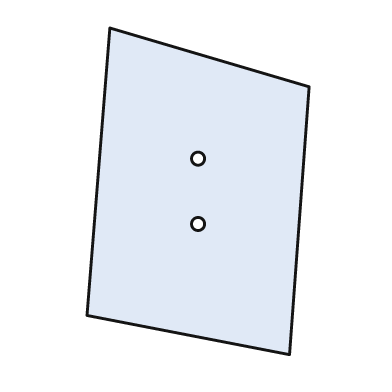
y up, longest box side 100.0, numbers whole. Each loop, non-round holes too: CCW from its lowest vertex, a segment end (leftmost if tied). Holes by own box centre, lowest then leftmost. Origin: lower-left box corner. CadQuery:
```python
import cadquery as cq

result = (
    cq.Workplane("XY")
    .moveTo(62.0, 0.0)
    .lineTo(68.0, 82.0)
    .lineTo(7.0, 100.0)
    .lineTo(0.0, 12.0)
    .close()
    .moveTo(34.0, 40.0)
    .circle(2.0)
    .moveTo(34.0, 60.0)
    .circle(2.0)
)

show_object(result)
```